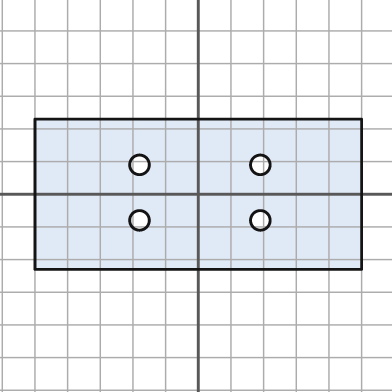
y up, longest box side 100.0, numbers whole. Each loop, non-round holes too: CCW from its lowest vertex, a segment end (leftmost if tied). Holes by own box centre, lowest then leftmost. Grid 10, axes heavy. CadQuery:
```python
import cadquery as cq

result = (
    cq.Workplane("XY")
    .moveTo(-50.0, -23.0)
    .lineTo(50.0, -23.0)
    .lineTo(50.0, 23.0)
    .lineTo(-50.0, 23.0)
    .close()
    .moveTo(-18.0, -8.0)
    .circle(3.0)
    .moveTo(19.0, -8.0)
    .circle(3.0)
    .moveTo(-18.0, 9.0)
    .circle(3.0)
    .moveTo(19.0, 9.0)
    .circle(3.0)
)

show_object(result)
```